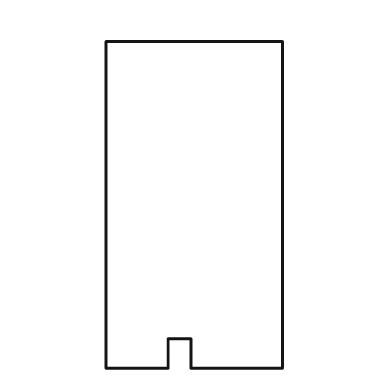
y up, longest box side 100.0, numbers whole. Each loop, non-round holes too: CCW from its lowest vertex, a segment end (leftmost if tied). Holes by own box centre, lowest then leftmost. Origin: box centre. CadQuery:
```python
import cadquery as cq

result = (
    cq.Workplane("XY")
    .moveTo(-27.0, -50.0)
    .lineTo(-8.0, -50.0)
    .lineTo(-8.0, -41.0)
    .lineTo(-1.0, -41.0)
    .lineTo(-1.0, -50.0)
    .lineTo(27.0, -50.0)
    .lineTo(27.0, 50.0)
    .lineTo(-27.0, 50.0)
    .close()
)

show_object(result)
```